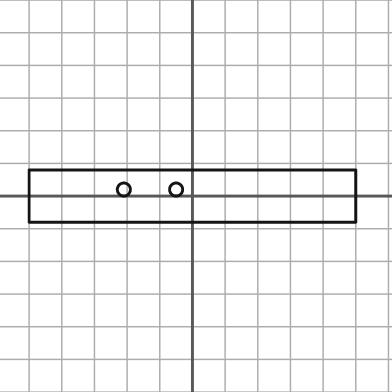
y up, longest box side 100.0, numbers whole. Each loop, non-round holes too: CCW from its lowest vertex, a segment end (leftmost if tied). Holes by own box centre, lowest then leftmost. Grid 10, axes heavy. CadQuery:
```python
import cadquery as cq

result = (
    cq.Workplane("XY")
    .moveTo(-50.0, -8.0)
    .lineTo(50.0, -8.0)
    .lineTo(50.0, 8.0)
    .lineTo(-50.0, 8.0)
    .close()
    .moveTo(-21.0, 2.0)
    .circle(2.0)
    .moveTo(-5.0, 2.0)
    .circle(2.0)
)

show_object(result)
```